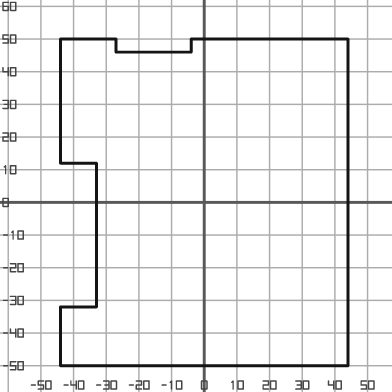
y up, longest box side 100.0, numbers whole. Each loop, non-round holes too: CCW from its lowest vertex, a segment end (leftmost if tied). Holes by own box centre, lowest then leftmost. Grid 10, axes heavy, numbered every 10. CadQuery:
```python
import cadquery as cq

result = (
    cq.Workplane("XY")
    .moveTo(-44.0, -50.0)
    .lineTo(44.0, -50.0)
    .lineTo(44.0, 50.0)
    .lineTo(-4.0, 50.0)
    .lineTo(-4.0, 46.0)
    .lineTo(-27.0, 46.0)
    .lineTo(-27.0, 50.0)
    .lineTo(-44.0, 50.0)
    .lineTo(-44.0, 12.0)
    .lineTo(-33.0, 12.0)
    .lineTo(-33.0, -32.0)
    .lineTo(-44.0, -32.0)
    .close()
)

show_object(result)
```